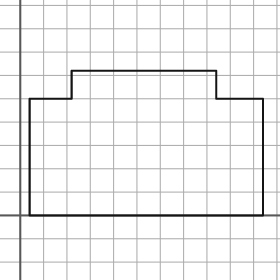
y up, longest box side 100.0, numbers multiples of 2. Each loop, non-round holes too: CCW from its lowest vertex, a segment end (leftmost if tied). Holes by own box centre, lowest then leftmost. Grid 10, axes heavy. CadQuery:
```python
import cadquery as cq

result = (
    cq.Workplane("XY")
    .moveTo(4.0, 0.0)
    .lineTo(104.0, 0.0)
    .lineTo(104.0, 50.0)
    .lineTo(84.0, 50.0)
    .lineTo(84.0, 62.0)
    .lineTo(22.0, 62.0)
    .lineTo(22.0, 50.0)
    .lineTo(4.0, 50.0)
    .close()
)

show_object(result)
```